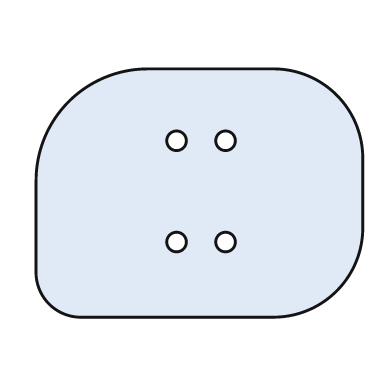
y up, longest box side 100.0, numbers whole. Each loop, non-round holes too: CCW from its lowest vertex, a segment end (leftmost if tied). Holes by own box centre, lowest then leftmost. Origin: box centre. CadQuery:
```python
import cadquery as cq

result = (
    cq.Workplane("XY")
    .moveTo(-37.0, -38.0)
    .lineTo(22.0, -38.0)
    .threePointArc((42.0, -30.0), (50.0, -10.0))
    .lineTo(50.0, 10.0)
    .threePointArc((42.0, 30.0), (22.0, 38.0))
    .lineTo(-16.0, 38.0)
    .threePointArc((-40.0, 28.0), (-50.0, 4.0))
    .lineTo(-50.0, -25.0)
    .threePointArc((-46.0, -34.0), (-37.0, -38.0))
    .close()
    .moveTo(-7.0, -15.0)
    .circle(3.0)
    .moveTo(8.0, -15.0)
    .circle(3.0)
    .moveTo(-7.0, 16.0)
    .circle(3.0)
    .moveTo(8.0, 16.0)
    .circle(3.0)
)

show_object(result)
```